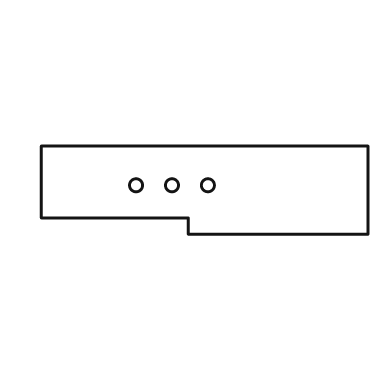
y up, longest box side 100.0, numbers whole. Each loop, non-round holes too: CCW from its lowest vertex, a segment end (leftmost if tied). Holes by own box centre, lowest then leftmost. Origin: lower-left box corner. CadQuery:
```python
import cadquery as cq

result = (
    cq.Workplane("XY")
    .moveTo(45.0, 0.0)
    .lineTo(100.0, 0.0)
    .lineTo(100.0, 27.0)
    .lineTo(0.0, 27.0)
    .lineTo(0.0, 5.0)
    .lineTo(45.0, 5.0)
    .close()
    .moveTo(29.0, 15.0)
    .circle(2.0)
    .moveTo(40.0, 15.0)
    .circle(2.0)
    .moveTo(51.0, 15.0)
    .circle(2.0)
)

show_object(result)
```